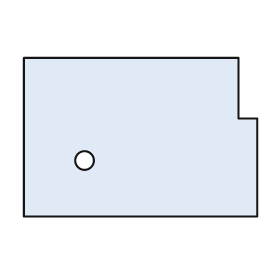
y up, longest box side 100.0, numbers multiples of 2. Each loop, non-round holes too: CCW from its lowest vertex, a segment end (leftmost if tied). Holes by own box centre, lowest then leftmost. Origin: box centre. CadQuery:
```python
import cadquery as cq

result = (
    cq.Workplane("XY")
    .moveTo(-50.0, -34.0)
    .lineTo(50.0, -34.0)
    .lineTo(50.0, 8.0)
    .lineTo(42.0, 8.0)
    .lineTo(42.0, 34.0)
    .lineTo(-50.0, 34.0)
    .close()
    .moveTo(-24.0, -10.0)
    .circle(4.0)
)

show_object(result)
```